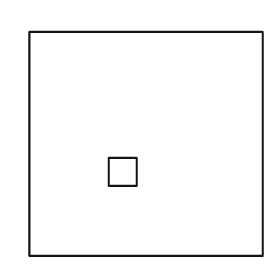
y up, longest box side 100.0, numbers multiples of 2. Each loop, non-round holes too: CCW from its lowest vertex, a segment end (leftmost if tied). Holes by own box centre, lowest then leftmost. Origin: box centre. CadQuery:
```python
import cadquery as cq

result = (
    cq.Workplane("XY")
    .moveTo(-50.0, -48.0)
    .lineTo(50.0, -48.0)
    .lineTo(50.0, 48.0)
    .lineTo(-50.0, 48.0)
    .close()
    .moveTo(-16.0, -18.0)
    .lineTo(-4.0, -18.0)
    .lineTo(-4.0, -6.0)
    .lineTo(-16.0, -6.0)
    .close()
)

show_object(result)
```